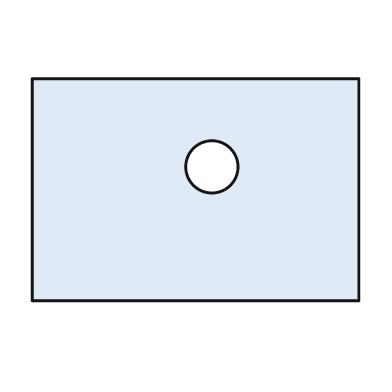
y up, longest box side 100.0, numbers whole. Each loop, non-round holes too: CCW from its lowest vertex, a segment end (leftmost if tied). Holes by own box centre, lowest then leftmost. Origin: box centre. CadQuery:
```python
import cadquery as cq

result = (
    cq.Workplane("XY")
    .moveTo(-50.0, -34.0)
    .lineTo(50.0, -34.0)
    .lineTo(50.0, 34.0)
    .lineTo(-50.0, 34.0)
    .close()
    .moveTo(5.0, 7.0)
    .circle(8.0)
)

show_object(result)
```